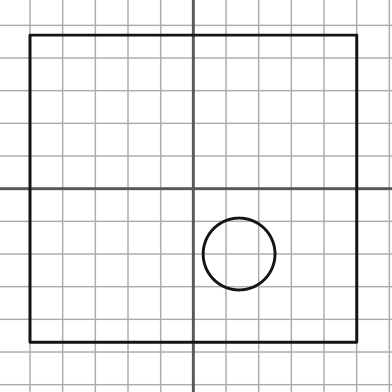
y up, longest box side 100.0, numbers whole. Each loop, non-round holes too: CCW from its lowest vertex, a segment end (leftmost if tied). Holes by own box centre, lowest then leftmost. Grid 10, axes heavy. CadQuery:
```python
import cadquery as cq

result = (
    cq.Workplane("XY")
    .moveTo(-50.0, -47.0)
    .lineTo(50.0, -47.0)
    .lineTo(50.0, 47.0)
    .lineTo(-50.0, 47.0)
    .close()
    .moveTo(14.0, -20.0)
    .circle(11.0)
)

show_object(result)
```